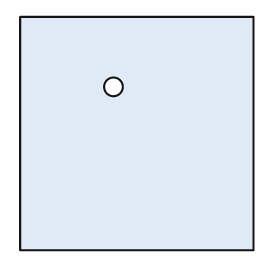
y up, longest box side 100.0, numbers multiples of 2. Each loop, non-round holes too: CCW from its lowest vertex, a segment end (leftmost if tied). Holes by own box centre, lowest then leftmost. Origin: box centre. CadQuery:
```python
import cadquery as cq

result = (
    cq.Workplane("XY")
    .moveTo(-50.0, -50.0)
    .lineTo(50.0, -50.0)
    .lineTo(50.0, 50.0)
    .lineTo(-50.0, 50.0)
    .close()
    .moveTo(-10.0, 20.0)
    .circle(4.0)
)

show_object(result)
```